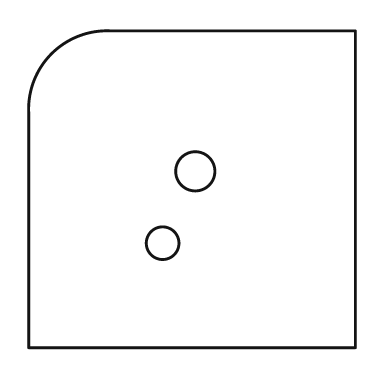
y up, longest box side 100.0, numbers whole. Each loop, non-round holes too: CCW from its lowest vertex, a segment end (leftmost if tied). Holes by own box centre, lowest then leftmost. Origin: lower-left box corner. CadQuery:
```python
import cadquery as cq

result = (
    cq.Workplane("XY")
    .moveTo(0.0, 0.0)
    .lineTo(100.0, 0.0)
    .lineTo(100.0, 97.0)
    .lineTo(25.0, 97.0)
    .threePointArc((7.0, 90.0), (0.0, 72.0))
    .close()
    .moveTo(41.0, 32.0)
    .circle(5.0)
    .moveTo(51.0, 54.0)
    .circle(6.0)
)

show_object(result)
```